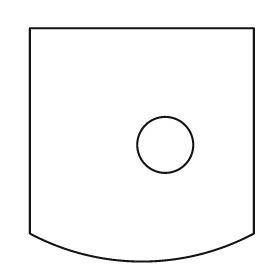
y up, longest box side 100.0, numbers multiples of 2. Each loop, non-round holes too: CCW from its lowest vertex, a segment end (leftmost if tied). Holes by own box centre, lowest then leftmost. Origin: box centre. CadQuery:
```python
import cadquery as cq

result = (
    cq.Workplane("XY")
    .moveTo(-48.0, -38.0)
    .threePointArc((0.0, -50.0), (48.0, -38.0))
    .lineTo(48.0, 50.0)
    .lineTo(-48.0, 50.0)
    .close()
    .moveTo(10.0, 0.0)
    .circle(12.0)
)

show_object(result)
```